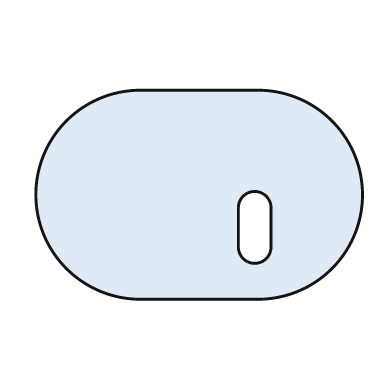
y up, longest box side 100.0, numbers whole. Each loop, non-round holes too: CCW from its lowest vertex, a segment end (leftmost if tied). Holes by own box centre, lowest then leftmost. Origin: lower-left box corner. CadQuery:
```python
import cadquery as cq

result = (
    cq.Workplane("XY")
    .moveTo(32.0, 0.0)
    .lineTo(68.0, 0.0)
    .threePointArc((100.0, 32.0), (68.0, 64.0))
    .lineTo(32.0, 64.0)
    .threePointArc((0.0, 32.0), (32.0, 0.0))
    .close()
    .moveTo(62.0, 16.0)
    .threePointArc((67.0, 11.0), (72.0, 16.0))
    .lineTo(72.0, 28.0)
    .threePointArc((67.0, 33.0), (62.0, 28.0))
    .close()
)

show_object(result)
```